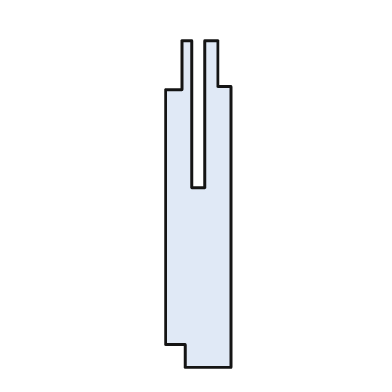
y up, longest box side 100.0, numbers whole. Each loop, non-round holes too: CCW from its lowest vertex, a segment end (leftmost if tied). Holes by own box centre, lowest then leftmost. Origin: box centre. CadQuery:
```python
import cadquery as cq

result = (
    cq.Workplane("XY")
    .moveTo(-4.0, -50.0)
    .lineTo(10.0, -50.0)
    .lineTo(10.0, 36.0)
    .lineTo(6.0, 36.0)
    .lineTo(6.0, 50.0)
    .lineTo(2.0, 50.0)
    .lineTo(2.0, 5.0)
    .lineTo(-2.0, 5.0)
    .lineTo(-2.0, 50.0)
    .lineTo(-5.0, 50.0)
    .lineTo(-5.0, 35.0)
    .lineTo(-10.0, 35.0)
    .lineTo(-10.0, -43.0)
    .lineTo(-4.0, -43.0)
    .close()
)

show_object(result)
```